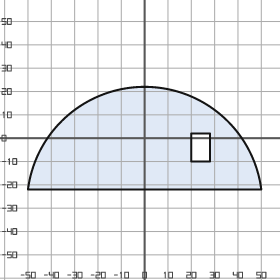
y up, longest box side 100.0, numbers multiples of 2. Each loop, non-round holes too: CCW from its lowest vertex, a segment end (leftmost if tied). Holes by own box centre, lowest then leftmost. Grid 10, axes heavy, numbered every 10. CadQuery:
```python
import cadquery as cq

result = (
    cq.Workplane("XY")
    .moveTo(-50.0, -22.0)
    .lineTo(50.0, -22.0)
    .threePointArc((0.0, 22.0), (-50.0, -22.0))
    .close()
    .moveTo(20.0, -10.0)
    .lineTo(28.0, -10.0)
    .lineTo(28.0, 2.0)
    .lineTo(20.0, 2.0)
    .close()
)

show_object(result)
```